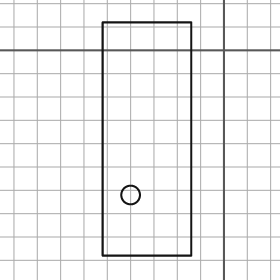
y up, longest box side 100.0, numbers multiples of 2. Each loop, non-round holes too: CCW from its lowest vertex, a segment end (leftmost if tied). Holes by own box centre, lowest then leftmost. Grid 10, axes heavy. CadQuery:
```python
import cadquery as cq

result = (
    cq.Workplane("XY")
    .moveTo(-52.0, -88.0)
    .lineTo(-14.0, -88.0)
    .lineTo(-14.0, 12.0)
    .lineTo(-52.0, 12.0)
    .close()
    .moveTo(-40.0, -62.0)
    .circle(4.0)
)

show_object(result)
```